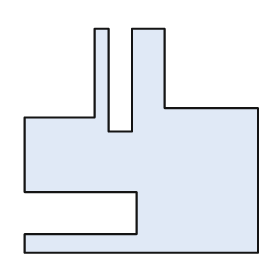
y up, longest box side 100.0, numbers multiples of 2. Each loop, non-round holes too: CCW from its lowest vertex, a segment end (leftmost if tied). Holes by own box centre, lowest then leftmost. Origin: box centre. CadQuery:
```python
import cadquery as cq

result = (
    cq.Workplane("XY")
    .moveTo(-50.0, -48.0)
    .lineTo(50.0, -48.0)
    .lineTo(50.0, 14.0)
    .lineTo(10.0, 14.0)
    .lineTo(10.0, 48.0)
    .lineTo(-4.0, 48.0)
    .lineTo(-4.0, 4.0)
    .lineTo(-14.0, 4.0)
    .lineTo(-14.0, 48.0)
    .lineTo(-20.0, 48.0)
    .lineTo(-20.0, 10.0)
    .lineTo(-50.0, 10.0)
    .lineTo(-50.0, -22.0)
    .lineTo(-2.0, -22.0)
    .lineTo(-2.0, -40.0)
    .lineTo(-50.0, -40.0)
    .close()
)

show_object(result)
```